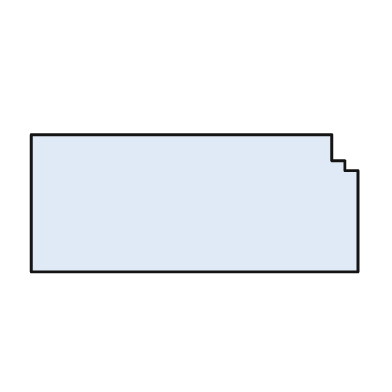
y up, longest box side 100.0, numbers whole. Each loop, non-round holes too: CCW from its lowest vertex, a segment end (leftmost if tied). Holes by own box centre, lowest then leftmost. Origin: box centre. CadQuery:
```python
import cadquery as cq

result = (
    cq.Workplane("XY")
    .moveTo(-50.0, -21.0)
    .lineTo(50.0, -21.0)
    .lineTo(50.0, 10.0)
    .lineTo(46.0, 10.0)
    .lineTo(46.0, 13.0)
    .lineTo(42.0, 13.0)
    .lineTo(42.0, 21.0)
    .lineTo(-50.0, 21.0)
    .close()
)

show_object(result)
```